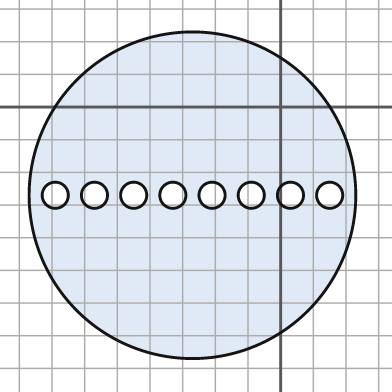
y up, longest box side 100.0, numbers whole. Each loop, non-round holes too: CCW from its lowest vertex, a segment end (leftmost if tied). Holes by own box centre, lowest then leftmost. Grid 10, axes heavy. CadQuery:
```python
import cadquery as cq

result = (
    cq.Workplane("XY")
    .moveTo(-27.0, -27.0)
    .circle(50.0)
    .moveTo(-69.0, -27.0)
    .circle(4.0)
    .moveTo(-57.0, -27.0)
    .circle(4.0)
    .moveTo(-45.0, -27.0)
    .circle(4.0)
    .moveTo(-33.0, -27.0)
    .circle(4.0)
    .moveTo(-21.0, -27.0)
    .circle(4.0)
    .moveTo(-9.0, -27.0)
    .circle(4.0)
    .moveTo(3.0, -27.0)
    .circle(4.0)
    .moveTo(15.0, -27.0)
    .circle(4.0)
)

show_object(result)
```